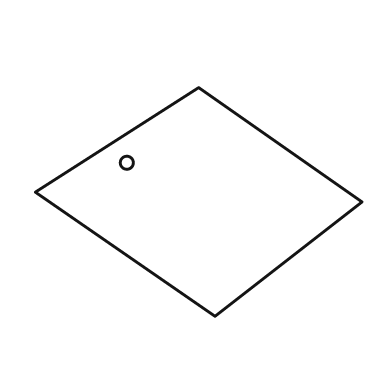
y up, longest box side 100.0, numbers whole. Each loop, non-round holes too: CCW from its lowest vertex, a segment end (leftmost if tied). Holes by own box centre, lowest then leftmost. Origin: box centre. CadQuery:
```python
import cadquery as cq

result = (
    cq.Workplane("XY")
    .moveTo(5.0, -35.0)
    .lineTo(50.0, 0.0)
    .lineTo(0.0, 35.0)
    .lineTo(-50.0, 3.0)
    .close()
    .moveTo(-22.0, 12.0)
    .circle(2.0)
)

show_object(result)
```